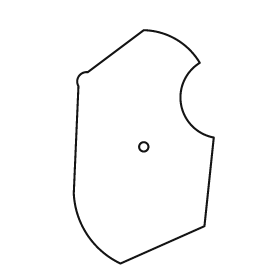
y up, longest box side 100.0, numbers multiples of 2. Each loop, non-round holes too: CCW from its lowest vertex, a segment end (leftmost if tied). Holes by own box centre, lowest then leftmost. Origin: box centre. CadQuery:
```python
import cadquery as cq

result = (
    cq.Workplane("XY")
    .moveTo(-10.0, -50.0)
    .lineTo(26.0, -34.0)
    .lineTo(30.0, 4.0)
    .threePointArc((16.0, 18.0), (24.0, 36.0))
    .threePointArc((14.0, 46.0), (0.0, 50.0))
    .lineTo(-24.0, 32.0)
    .threePointArc((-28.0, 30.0), (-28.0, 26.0))
    .lineTo(-30.0, -20.0)
    .threePointArc((-24.0, -38.0), (-10.0, -50.0))
    .close()
    .moveTo(0.0, 0.0)
    .circle(2.0)
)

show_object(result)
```